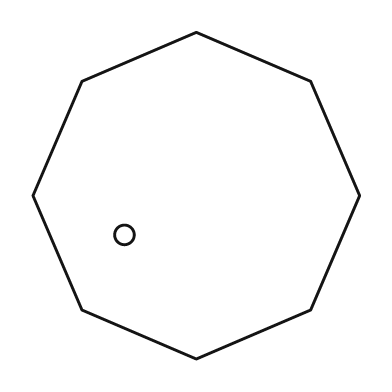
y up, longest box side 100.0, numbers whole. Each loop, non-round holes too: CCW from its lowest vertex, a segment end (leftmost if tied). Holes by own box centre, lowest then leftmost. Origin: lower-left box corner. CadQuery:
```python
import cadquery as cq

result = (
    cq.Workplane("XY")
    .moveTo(50.0, 0.0)
    .lineTo(85.0, 15.0)
    .lineTo(100.0, 50.0)
    .lineTo(85.0, 85.0)
    .lineTo(50.0, 100.0)
    .lineTo(15.0, 85.0)
    .lineTo(0.0, 50.0)
    .lineTo(15.0, 15.0)
    .close()
    .moveTo(28.0, 38.0)
    .circle(3.0)
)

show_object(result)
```